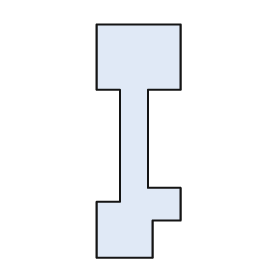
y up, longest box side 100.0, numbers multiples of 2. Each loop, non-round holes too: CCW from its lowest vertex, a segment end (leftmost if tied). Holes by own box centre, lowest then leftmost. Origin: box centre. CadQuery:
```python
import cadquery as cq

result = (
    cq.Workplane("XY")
    .moveTo(-18.0, -50.0)
    .lineTo(6.0, -50.0)
    .lineTo(6.0, -34.0)
    .lineTo(18.0, -34.0)
    .lineTo(18.0, -20.0)
    .lineTo(4.0, -20.0)
    .lineTo(4.0, 22.0)
    .lineTo(18.0, 22.0)
    .lineTo(18.0, 50.0)
    .lineTo(-18.0, 50.0)
    .lineTo(-18.0, 22.0)
    .lineTo(-8.0, 22.0)
    .lineTo(-8.0, -26.0)
    .lineTo(-18.0, -26.0)
    .close()
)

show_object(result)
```